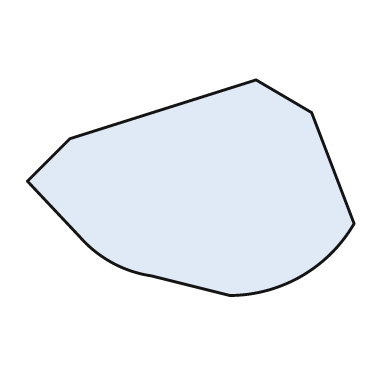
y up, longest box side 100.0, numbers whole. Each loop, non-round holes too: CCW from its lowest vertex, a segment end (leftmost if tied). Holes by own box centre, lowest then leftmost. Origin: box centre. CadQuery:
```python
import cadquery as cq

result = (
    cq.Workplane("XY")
    .moveTo(12.0, -33.0)
    .threePointArc((34.0, -27.0), (50.0, -11.0))
    .lineTo(37.0, 23.0)
    .lineTo(20.0, 33.0)
    .lineTo(-37.0, 15.0)
    .lineTo(-50.0, 2.0)
    .lineTo(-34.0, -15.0)
    .threePointArc((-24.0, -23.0), (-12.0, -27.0))
    .close()
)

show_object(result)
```